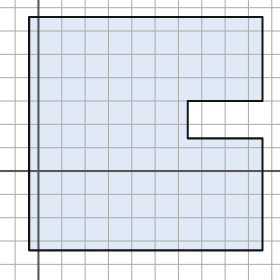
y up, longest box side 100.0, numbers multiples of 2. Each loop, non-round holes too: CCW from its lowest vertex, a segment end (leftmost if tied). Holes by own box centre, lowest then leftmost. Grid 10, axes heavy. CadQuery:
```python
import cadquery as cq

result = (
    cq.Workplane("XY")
    .moveTo(-4.0, -34.0)
    .lineTo(96.0, -34.0)
    .lineTo(96.0, 14.0)
    .lineTo(64.0, 14.0)
    .lineTo(64.0, 30.0)
    .lineTo(96.0, 30.0)
    .lineTo(96.0, 66.0)
    .lineTo(-4.0, 66.0)
    .close()
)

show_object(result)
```